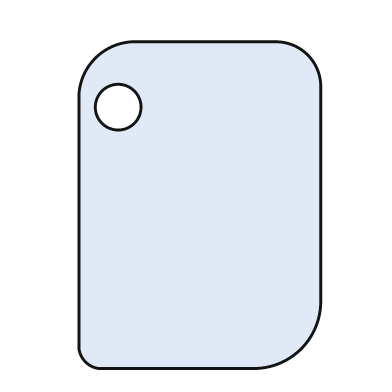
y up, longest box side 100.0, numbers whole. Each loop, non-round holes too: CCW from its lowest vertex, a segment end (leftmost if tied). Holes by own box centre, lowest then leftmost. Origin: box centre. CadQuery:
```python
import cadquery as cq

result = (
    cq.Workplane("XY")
    .moveTo(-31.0, -50.0)
    .lineTo(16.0, -50.0)
    .threePointArc((31.0, -44.0), (37.0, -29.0))
    .lineTo(37.0, 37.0)
    .threePointArc((33.0, 46.0), (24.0, 50.0))
    .lineTo(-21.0, 50.0)
    .threePointArc((-32.0, 45.0), (-37.0, 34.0))
    .lineTo(-37.0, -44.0)
    .threePointArc((-35.0, -48.0), (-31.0, -50.0))
    .close()
    .moveTo(-25.0, 30.0)
    .circle(7.0)
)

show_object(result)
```